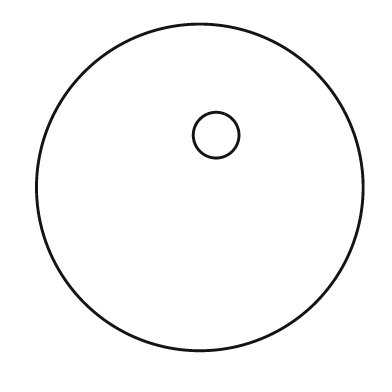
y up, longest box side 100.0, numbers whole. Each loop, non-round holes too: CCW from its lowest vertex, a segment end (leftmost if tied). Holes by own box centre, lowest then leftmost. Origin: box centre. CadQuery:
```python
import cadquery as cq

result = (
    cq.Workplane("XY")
    .moveTo(0.0, 0.0)
    .circle(50.0)
    .moveTo(5.0, 16.0)
    .circle(7.0)
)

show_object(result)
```